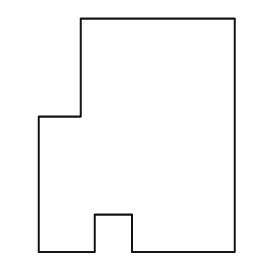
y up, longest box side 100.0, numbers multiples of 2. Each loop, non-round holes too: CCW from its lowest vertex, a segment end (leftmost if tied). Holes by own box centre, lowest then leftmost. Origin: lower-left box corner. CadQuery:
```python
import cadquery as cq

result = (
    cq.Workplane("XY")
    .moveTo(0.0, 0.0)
    .lineTo(24.0, 0.0)
    .lineTo(24.0, 16.0)
    .lineTo(40.0, 16.0)
    .lineTo(40.0, 0.0)
    .lineTo(84.0, 0.0)
    .lineTo(84.0, 100.0)
    .lineTo(18.0, 100.0)
    .lineTo(18.0, 58.0)
    .lineTo(0.0, 58.0)
    .close()
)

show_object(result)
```